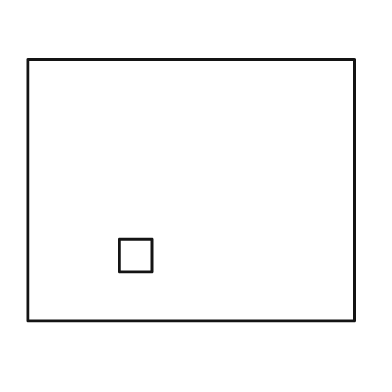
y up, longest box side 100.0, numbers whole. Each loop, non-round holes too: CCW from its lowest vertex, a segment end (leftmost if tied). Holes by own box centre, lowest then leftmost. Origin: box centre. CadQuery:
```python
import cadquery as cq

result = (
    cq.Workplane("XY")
    .moveTo(-50.0, -40.0)
    .lineTo(50.0, -40.0)
    .lineTo(50.0, 40.0)
    .lineTo(-50.0, 40.0)
    .close()
    .moveTo(-22.0, -25.0)
    .lineTo(-12.0, -25.0)
    .lineTo(-12.0, -15.0)
    .lineTo(-22.0, -15.0)
    .close()
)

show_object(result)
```